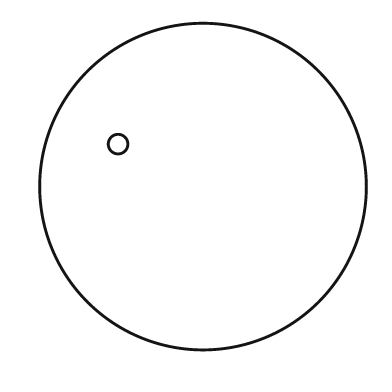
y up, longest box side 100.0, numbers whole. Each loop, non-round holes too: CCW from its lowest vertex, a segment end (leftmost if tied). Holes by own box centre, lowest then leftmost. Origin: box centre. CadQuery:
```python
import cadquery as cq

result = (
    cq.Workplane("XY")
    .moveTo(0.0, 0.0)
    .circle(50.0)
    .moveTo(-26.0, 13.0)
    .circle(3.0)
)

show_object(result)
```